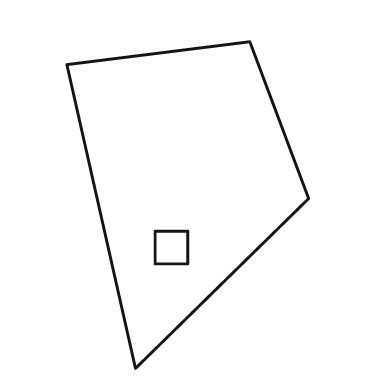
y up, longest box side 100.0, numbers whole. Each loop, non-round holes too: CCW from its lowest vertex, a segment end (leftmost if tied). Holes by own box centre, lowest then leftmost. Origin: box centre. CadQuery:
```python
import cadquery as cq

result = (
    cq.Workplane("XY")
    .moveTo(-16.0, -50.0)
    .lineTo(37.0, 2.0)
    .lineTo(19.0, 50.0)
    .lineTo(-37.0, 43.0)
    .close()
    .moveTo(-10.0, -18.0)
    .lineTo(0.0, -18.0)
    .lineTo(0.0, -8.0)
    .lineTo(-10.0, -8.0)
    .close()
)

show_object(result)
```